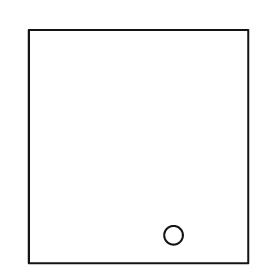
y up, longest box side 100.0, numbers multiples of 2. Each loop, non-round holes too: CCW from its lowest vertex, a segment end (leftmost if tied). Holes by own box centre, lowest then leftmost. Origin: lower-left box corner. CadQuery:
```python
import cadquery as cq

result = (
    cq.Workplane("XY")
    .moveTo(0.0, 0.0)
    .lineTo(94.0, 0.0)
    .lineTo(94.0, 100.0)
    .lineTo(0.0, 100.0)
    .close()
    .moveTo(62.0, 12.0)
    .circle(4.0)
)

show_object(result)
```